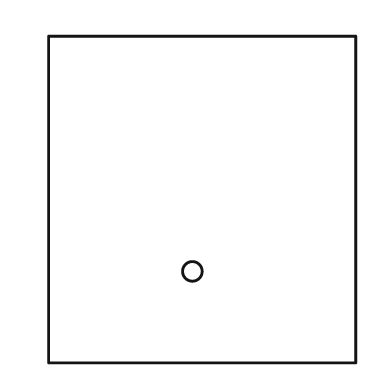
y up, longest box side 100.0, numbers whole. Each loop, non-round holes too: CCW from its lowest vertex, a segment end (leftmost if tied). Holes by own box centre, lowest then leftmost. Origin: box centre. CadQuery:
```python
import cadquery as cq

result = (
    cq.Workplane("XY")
    .moveTo(-47.0, -50.0)
    .lineTo(47.0, -50.0)
    .lineTo(47.0, 50.0)
    .lineTo(-47.0, 50.0)
    .close()
    .moveTo(-3.0, -22.0)
    .circle(3.0)
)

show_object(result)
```